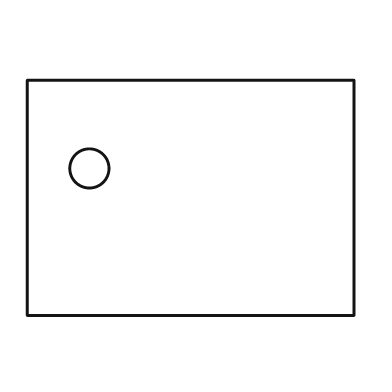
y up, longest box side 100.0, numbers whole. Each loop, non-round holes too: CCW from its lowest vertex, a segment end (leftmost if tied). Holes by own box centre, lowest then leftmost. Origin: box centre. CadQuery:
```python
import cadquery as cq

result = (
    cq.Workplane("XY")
    .moveTo(-50.0, -36.0)
    .lineTo(50.0, -36.0)
    .lineTo(50.0, 36.0)
    .lineTo(-50.0, 36.0)
    .close()
    .moveTo(-31.0, 9.0)
    .circle(6.0)
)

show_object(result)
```